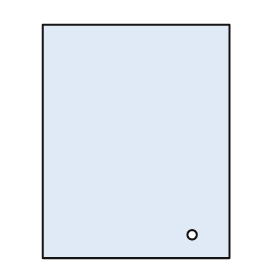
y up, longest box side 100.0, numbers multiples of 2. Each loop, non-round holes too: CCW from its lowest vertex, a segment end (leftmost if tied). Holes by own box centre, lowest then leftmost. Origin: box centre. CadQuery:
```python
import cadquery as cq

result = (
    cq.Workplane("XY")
    .moveTo(-40.0, -50.0)
    .lineTo(40.0, -50.0)
    .lineTo(40.0, 50.0)
    .lineTo(-40.0, 50.0)
    .close()
    .moveTo(24.0, -40.0)
    .circle(2.0)
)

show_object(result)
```